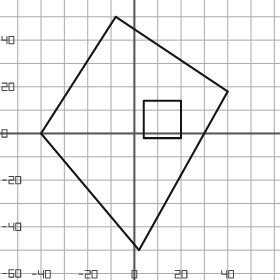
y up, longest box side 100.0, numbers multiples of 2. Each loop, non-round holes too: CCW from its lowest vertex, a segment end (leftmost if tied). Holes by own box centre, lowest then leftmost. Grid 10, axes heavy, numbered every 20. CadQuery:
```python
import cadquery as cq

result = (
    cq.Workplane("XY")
    .moveTo(2.0, -50.0)
    .lineTo(40.0, 18.0)
    .lineTo(-8.0, 50.0)
    .lineTo(-40.0, 0.0)
    .close()
    .moveTo(4.0, -2.0)
    .lineTo(20.0, -2.0)
    .lineTo(20.0, 14.0)
    .lineTo(4.0, 14.0)
    .close()
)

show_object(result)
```